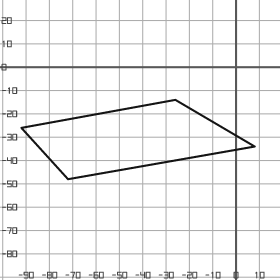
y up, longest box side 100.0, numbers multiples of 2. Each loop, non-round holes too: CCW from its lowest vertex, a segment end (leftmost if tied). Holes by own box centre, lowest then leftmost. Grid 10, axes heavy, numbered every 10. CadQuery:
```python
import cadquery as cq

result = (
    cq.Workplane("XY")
    .moveTo(-72.0, -48.0)
    .lineTo(8.0, -34.0)
    .lineTo(-26.0, -14.0)
    .lineTo(-92.0, -26.0)
    .close()
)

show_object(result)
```